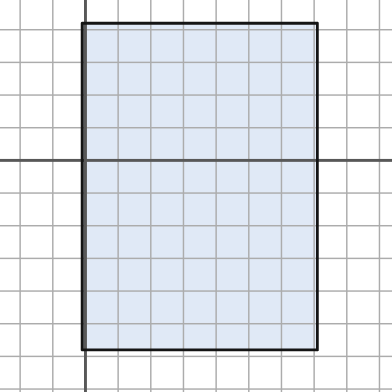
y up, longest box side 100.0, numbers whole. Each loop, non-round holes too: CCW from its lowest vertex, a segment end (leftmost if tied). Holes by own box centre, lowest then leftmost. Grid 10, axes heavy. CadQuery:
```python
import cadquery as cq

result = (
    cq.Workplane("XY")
    .moveTo(-1.0, -58.0)
    .lineTo(71.0, -58.0)
    .lineTo(71.0, 42.0)
    .lineTo(-1.0, 42.0)
    .close()
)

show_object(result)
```